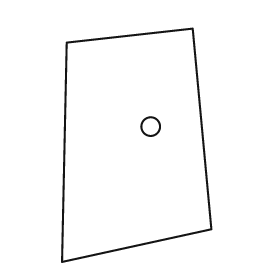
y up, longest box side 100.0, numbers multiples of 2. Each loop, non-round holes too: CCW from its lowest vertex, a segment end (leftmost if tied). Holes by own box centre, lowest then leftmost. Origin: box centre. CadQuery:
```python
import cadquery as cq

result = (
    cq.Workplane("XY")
    .moveTo(-32.0, -50.0)
    .lineTo(32.0, -36.0)
    .lineTo(24.0, 50.0)
    .lineTo(-30.0, 44.0)
    .close()
    .moveTo(6.0, 8.0)
    .circle(4.0)
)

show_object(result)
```